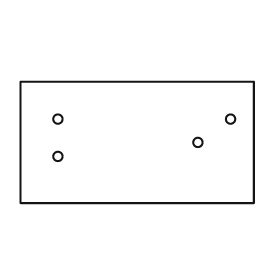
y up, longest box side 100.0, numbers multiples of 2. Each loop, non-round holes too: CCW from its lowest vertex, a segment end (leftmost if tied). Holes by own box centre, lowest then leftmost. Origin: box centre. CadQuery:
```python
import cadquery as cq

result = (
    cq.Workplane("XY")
    .moveTo(-50.0, -26.0)
    .lineTo(50.0, -26.0)
    .lineTo(50.0, 26.0)
    .lineTo(-50.0, 26.0)
    .close()
    .moveTo(-34.0, -6.0)
    .circle(2.0)
    .moveTo(26.0, 0.0)
    .circle(2.0)
    .moveTo(-34.0, 10.0)
    .circle(2.0)
    .moveTo(40.0, 10.0)
    .circle(2.0)
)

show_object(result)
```